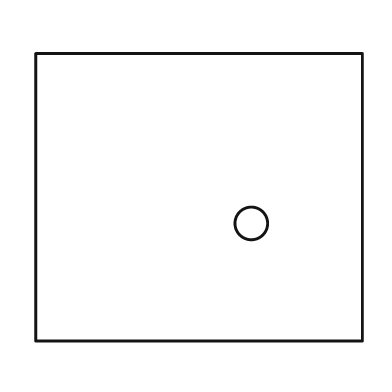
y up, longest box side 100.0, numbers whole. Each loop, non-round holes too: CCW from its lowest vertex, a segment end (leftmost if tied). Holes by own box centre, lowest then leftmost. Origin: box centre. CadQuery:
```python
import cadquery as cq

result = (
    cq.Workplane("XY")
    .moveTo(-50.0, -44.0)
    .lineTo(50.0, -44.0)
    .lineTo(50.0, 44.0)
    .lineTo(-50.0, 44.0)
    .close()
    .moveTo(16.0, -8.0)
    .circle(5.0)
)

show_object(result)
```